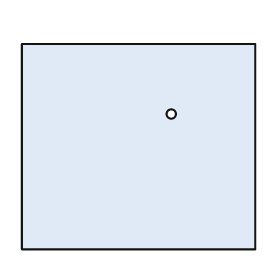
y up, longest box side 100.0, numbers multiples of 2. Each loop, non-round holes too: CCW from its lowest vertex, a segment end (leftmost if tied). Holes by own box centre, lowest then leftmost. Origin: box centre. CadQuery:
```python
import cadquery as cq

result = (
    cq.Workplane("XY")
    .moveTo(-50.0, -44.0)
    .lineTo(50.0, -44.0)
    .lineTo(50.0, 44.0)
    .lineTo(-50.0, 44.0)
    .close()
    .moveTo(14.0, 14.0)
    .circle(2.0)
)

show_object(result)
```